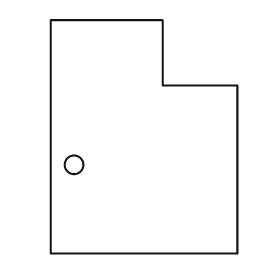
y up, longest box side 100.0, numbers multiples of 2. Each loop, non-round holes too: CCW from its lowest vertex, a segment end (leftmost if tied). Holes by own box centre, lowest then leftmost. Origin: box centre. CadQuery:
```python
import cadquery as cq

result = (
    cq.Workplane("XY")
    .moveTo(-40.0, -50.0)
    .lineTo(40.0, -50.0)
    .lineTo(40.0, 22.0)
    .lineTo(8.0, 22.0)
    .lineTo(8.0, 50.0)
    .lineTo(-40.0, 50.0)
    .close()
    .moveTo(-30.0, -12.0)
    .circle(4.0)
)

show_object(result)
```